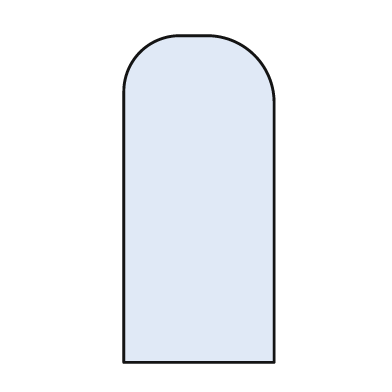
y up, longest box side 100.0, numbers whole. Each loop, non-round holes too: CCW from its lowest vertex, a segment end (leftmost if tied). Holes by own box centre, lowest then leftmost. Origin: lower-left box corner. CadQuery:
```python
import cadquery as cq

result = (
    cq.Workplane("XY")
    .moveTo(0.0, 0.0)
    .lineTo(46.0, 0.0)
    .lineTo(46.0, 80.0)
    .threePointArc((40.0, 94.0), (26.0, 100.0))
    .lineTo(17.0, 100.0)
    .threePointArc((5.0, 95.0), (0.0, 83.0))
    .close()
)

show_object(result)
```